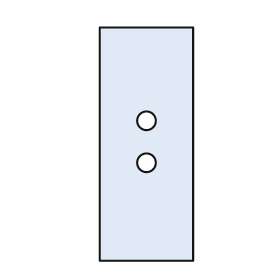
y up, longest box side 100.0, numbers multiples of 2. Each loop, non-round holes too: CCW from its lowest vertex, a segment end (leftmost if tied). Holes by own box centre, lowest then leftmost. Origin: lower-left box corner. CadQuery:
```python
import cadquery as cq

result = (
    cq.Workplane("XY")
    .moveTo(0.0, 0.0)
    .lineTo(40.0, 0.0)
    .lineTo(40.0, 100.0)
    .lineTo(0.0, 100.0)
    .close()
    .moveTo(20.0, 42.0)
    .circle(4.0)
    .moveTo(20.0, 60.0)
    .circle(4.0)
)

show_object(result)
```